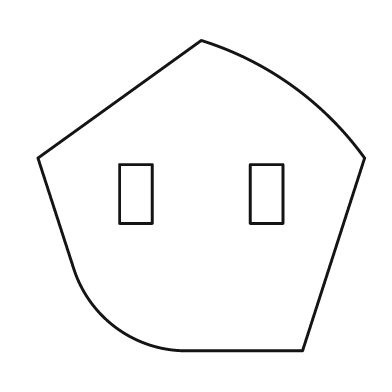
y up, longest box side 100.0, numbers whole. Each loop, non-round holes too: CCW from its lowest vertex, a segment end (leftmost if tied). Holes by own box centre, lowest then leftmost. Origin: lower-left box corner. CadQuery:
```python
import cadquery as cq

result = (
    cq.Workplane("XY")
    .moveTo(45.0, 0.0)
    .lineTo(81.0, 0.0)
    .lineTo(100.0, 59.0)
    .threePointArc((78.0, 81.0), (50.0, 95.0))
    .lineTo(0.0, 59.0)
    .lineTo(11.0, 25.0)
    .threePointArc((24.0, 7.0), (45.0, 0.0))
    .close()
    .moveTo(25.0, 39.0)
    .lineTo(35.0, 39.0)
    .lineTo(35.0, 57.0)
    .lineTo(25.0, 57.0)
    .close()
    .moveTo(65.0, 39.0)
    .lineTo(75.0, 39.0)
    .lineTo(75.0, 57.0)
    .lineTo(65.0, 57.0)
    .close()
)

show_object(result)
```